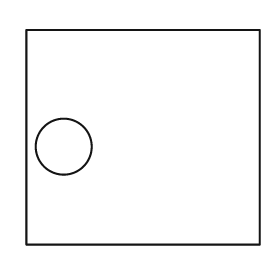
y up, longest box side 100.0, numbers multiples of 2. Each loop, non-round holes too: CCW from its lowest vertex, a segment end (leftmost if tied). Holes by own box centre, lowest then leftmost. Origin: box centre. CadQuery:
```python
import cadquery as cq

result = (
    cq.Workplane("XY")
    .moveTo(-50.0, -46.0)
    .lineTo(50.0, -46.0)
    .lineTo(50.0, 46.0)
    .lineTo(-50.0, 46.0)
    .close()
    .moveTo(-34.0, -4.0)
    .circle(12.0)
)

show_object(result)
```